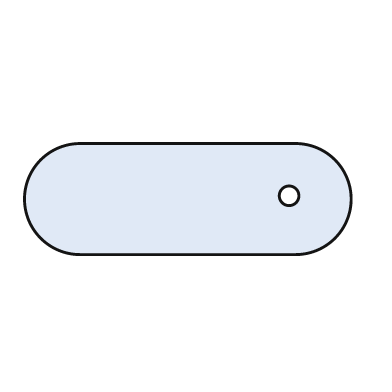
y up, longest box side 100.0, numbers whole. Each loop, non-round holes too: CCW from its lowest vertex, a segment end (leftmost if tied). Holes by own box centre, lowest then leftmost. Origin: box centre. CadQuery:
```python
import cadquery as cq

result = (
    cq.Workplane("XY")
    .moveTo(-33.0, -17.0)
    .lineTo(33.0, -17.0)
    .threePointArc((50.0, 0.0), (33.0, 17.0))
    .lineTo(-33.0, 17.0)
    .threePointArc((-50.0, 0.0), (-33.0, -17.0))
    .close()
    .moveTo(31.0, 1.0)
    .circle(3.0)
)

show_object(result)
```